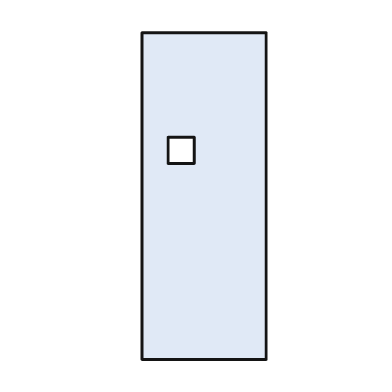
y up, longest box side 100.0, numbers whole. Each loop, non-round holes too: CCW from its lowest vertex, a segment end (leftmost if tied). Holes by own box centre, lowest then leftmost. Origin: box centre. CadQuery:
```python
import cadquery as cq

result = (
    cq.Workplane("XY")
    .moveTo(-19.0, -50.0)
    .lineTo(19.0, -50.0)
    .lineTo(19.0, 50.0)
    .lineTo(-19.0, 50.0)
    .close()
    .moveTo(-11.0, 10.0)
    .lineTo(-3.0, 10.0)
    .lineTo(-3.0, 18.0)
    .lineTo(-11.0, 18.0)
    .close()
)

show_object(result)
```